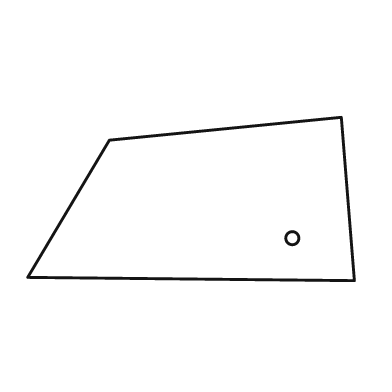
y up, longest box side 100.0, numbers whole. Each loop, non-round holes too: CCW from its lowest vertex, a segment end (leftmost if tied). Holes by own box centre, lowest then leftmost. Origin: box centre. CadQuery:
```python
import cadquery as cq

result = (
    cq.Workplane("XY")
    .moveTo(50.0, -25.0)
    .lineTo(46.0, 25.0)
    .lineTo(-25.0, 18.0)
    .lineTo(-50.0, -24.0)
    .close()
    .moveTo(31.0, -12.0)
    .circle(2.0)
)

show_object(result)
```